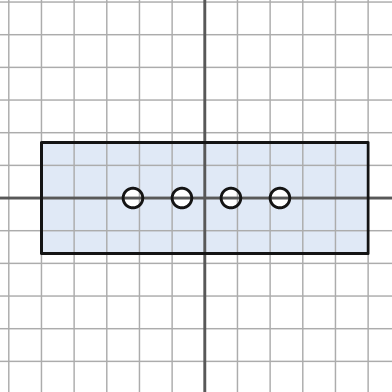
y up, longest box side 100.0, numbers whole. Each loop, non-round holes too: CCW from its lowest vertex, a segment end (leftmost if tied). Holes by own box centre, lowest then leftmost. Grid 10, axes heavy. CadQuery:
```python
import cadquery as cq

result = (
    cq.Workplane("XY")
    .moveTo(-50.0, -17.0)
    .lineTo(50.0, -17.0)
    .lineTo(50.0, 17.0)
    .lineTo(-50.0, 17.0)
    .close()
    .moveTo(-22.0, 0.0)
    .circle(3.0)
    .moveTo(-7.0, 0.0)
    .circle(3.0)
    .moveTo(8.0, 0.0)
    .circle(3.0)
    .moveTo(23.0, 0.0)
    .circle(3.0)
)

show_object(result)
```